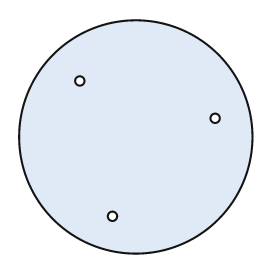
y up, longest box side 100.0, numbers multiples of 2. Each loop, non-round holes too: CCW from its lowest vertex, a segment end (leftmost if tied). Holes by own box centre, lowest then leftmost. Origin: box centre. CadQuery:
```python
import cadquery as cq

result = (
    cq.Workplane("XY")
    .moveTo(0.0, 0.0)
    .circle(50.0)
    .moveTo(-10.0, -34.0)
    .circle(2.0)
    .moveTo(34.0, 8.0)
    .circle(2.0)
    .moveTo(-24.0, 24.0)
    .circle(2.0)
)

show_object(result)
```